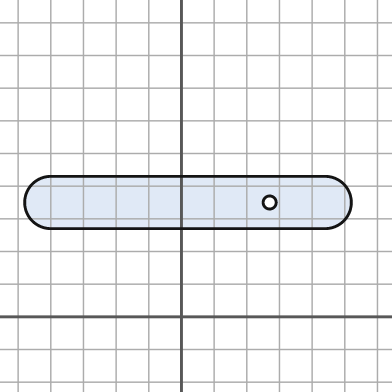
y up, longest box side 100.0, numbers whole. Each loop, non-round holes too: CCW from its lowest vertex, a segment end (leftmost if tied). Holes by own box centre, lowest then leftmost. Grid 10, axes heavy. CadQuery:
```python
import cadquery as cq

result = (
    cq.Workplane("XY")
    .moveTo(-40.0, 27.0)
    .lineTo(44.0, 27.0)
    .threePointArc((52.0, 35.0), (44.0, 43.0))
    .lineTo(-40.0, 43.0)
    .threePointArc((-48.0, 35.0), (-40.0, 27.0))
    .close()
    .moveTo(27.0, 35.0)
    .circle(2.0)
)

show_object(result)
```